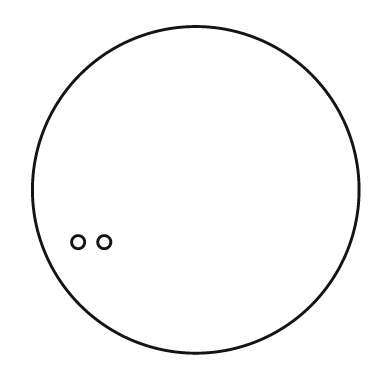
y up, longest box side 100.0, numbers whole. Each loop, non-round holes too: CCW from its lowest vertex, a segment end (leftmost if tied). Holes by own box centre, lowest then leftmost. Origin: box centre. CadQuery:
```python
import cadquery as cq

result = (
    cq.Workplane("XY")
    .moveTo(0.0, 0.0)
    .circle(50.0)
    .moveTo(-36.0, -16.0)
    .circle(2.0)
    .moveTo(-28.0, -16.0)
    .circle(2.0)
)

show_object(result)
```